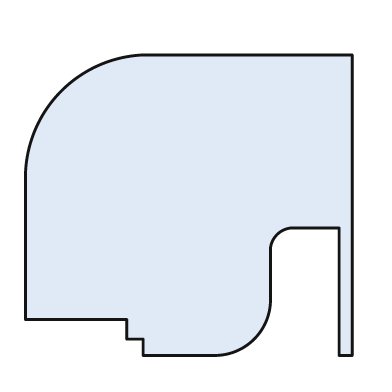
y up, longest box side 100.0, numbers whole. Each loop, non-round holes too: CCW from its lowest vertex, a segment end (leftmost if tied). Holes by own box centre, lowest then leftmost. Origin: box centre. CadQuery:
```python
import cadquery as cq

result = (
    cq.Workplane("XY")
    .moveTo(-14.0, -46.0)
    .lineTo(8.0, -46.0)
    .threePointArc((20.0, -41.0), (25.0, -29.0))
    .lineTo(25.0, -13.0)
    .threePointArc((27.0, -9.0), (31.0, -7.0))
    .lineTo(46.0, -7.0)
    .lineTo(46.0, -46.0)
    .lineTo(50.0, -46.0)
    .lineTo(50.0, 46.0)
    .lineTo(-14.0, 46.0)
    .threePointArc((-39.0, 35.0), (-50.0, 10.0))
    .lineTo(-50.0, -35.0)
    .lineTo(-19.0, -35.0)
    .lineTo(-19.0, -41.0)
    .lineTo(-14.0, -41.0)
    .close()
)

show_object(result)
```